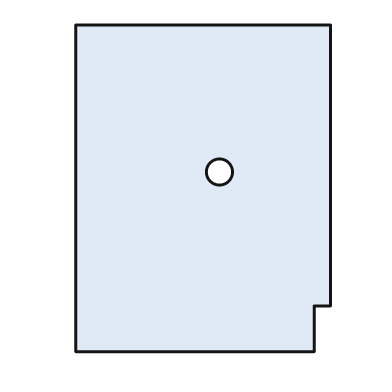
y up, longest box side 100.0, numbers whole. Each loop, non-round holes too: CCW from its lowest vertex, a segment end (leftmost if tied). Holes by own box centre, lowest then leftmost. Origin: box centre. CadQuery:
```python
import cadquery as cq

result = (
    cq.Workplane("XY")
    .moveTo(-39.0, -50.0)
    .lineTo(34.0, -50.0)
    .lineTo(34.0, -36.0)
    .lineTo(39.0, -36.0)
    .lineTo(39.0, 50.0)
    .lineTo(-39.0, 50.0)
    .close()
    .moveTo(5.0, 5.0)
    .circle(4.0)
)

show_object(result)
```